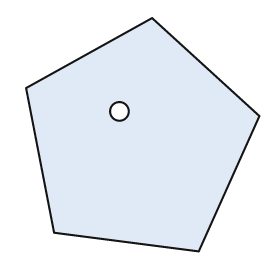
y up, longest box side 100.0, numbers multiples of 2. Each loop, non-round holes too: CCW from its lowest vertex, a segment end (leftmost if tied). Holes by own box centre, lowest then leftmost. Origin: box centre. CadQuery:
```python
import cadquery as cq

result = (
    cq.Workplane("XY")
    .moveTo(24.0, -50.0)
    .lineTo(50.0, 8.0)
    .lineTo(4.0, 50.0)
    .lineTo(-50.0, 20.0)
    .lineTo(-38.0, -42.0)
    .close()
    .moveTo(-10.0, 10.0)
    .circle(4.0)
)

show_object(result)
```